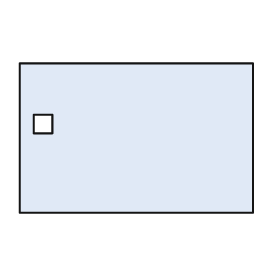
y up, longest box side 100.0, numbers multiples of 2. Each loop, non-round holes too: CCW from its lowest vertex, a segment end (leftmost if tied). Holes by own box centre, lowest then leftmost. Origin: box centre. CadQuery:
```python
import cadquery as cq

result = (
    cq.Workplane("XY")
    .moveTo(-50.0, -32.0)
    .lineTo(50.0, -32.0)
    .lineTo(50.0, 32.0)
    .lineTo(-50.0, 32.0)
    .close()
    .moveTo(-44.0, 2.0)
    .lineTo(-36.0, 2.0)
    .lineTo(-36.0, 10.0)
    .lineTo(-44.0, 10.0)
    .close()
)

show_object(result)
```